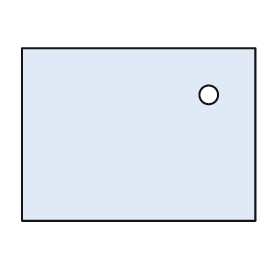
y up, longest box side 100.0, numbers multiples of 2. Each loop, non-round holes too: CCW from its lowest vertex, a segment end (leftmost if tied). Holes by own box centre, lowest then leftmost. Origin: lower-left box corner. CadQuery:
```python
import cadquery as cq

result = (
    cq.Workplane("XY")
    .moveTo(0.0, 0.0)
    .lineTo(100.0, 0.0)
    .lineTo(100.0, 74.0)
    .lineTo(0.0, 74.0)
    .close()
    .moveTo(80.0, 54.0)
    .circle(4.0)
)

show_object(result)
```